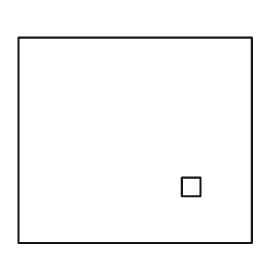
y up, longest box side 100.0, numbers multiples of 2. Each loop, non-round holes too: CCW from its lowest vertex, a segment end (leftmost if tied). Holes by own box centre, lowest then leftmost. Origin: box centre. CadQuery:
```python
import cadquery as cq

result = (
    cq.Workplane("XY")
    .moveTo(-50.0, -44.0)
    .lineTo(50.0, -44.0)
    .lineTo(50.0, 44.0)
    .lineTo(-50.0, 44.0)
    .close()
    .moveTo(20.0, -24.0)
    .lineTo(28.0, -24.0)
    .lineTo(28.0, -16.0)
    .lineTo(20.0, -16.0)
    .close()
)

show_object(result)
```